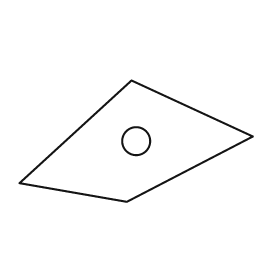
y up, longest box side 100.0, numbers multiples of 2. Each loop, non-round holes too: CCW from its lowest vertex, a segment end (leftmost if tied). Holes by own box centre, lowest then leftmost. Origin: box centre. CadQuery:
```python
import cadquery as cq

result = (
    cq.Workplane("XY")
    .moveTo(-4.0, -26.0)
    .lineTo(50.0, 2.0)
    .lineTo(-2.0, 26.0)
    .lineTo(-50.0, -18.0)
    .close()
    .moveTo(0.0, 0.0)
    .circle(6.0)
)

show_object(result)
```